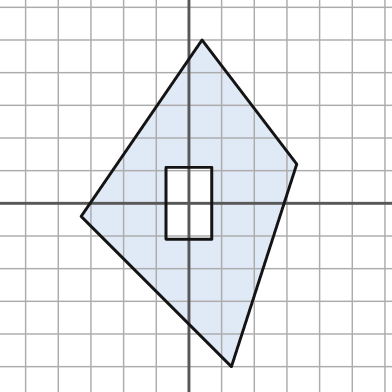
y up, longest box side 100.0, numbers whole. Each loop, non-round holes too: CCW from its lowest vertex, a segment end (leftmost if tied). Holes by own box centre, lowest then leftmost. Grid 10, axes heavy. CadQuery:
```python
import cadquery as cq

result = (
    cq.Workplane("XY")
    .moveTo(13.0, -50.0)
    .lineTo(33.0, 12.0)
    .lineTo(4.0, 50.0)
    .lineTo(-33.0, -4.0)
    .close()
    .moveTo(-7.0, -11.0)
    .lineTo(7.0, -11.0)
    .lineTo(7.0, 11.0)
    .lineTo(-7.0, 11.0)
    .close()
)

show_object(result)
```